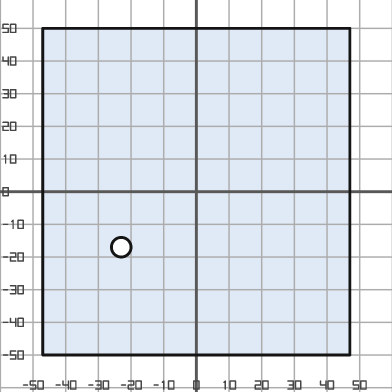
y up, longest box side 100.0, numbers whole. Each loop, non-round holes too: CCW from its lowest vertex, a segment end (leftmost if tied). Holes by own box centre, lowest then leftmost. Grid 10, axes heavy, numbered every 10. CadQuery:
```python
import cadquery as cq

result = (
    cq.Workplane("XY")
    .moveTo(-47.0, -50.0)
    .lineTo(47.0, -50.0)
    .lineTo(47.0, 50.0)
    .lineTo(-47.0, 50.0)
    .close()
    .moveTo(-23.0, -17.0)
    .circle(3.0)
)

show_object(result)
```